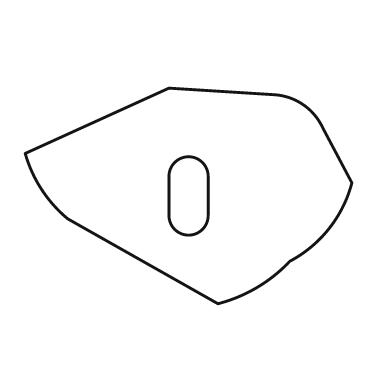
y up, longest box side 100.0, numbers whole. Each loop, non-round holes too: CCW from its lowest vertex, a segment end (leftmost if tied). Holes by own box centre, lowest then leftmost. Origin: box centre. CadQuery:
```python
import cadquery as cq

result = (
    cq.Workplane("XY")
    .moveTo(9.0, -33.0)
    .threePointArc((21.0, -28.0), (31.0, -20.0))
    .threePointArc((43.0, -10.0), (50.0, 4.0))
    .lineTo(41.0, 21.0)
    .threePointArc((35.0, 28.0), (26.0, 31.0))
    .lineTo(-6.0, 33.0)
    .lineTo(-50.0, 13.0)
    .threePointArc((-45.0, 2.0), (-37.0, -7.0))
    .close()
    .moveTo(-6.0, -6.0)
    .threePointArc((0.0, -12.0), (6.0, -6.0))
    .lineTo(6.0, 6.0)
    .threePointArc((0.0, 12.0), (-6.0, 6.0))
    .close()
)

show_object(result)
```